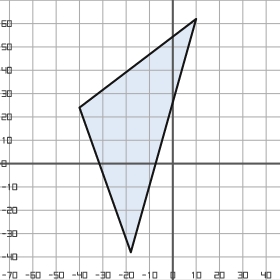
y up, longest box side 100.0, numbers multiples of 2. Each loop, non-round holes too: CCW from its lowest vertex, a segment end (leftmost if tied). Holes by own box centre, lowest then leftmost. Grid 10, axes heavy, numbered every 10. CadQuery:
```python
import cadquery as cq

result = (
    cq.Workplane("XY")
    .moveTo(-18.0, -38.0)
    .lineTo(10.0, 62.0)
    .lineTo(-40.0, 24.0)
    .close()
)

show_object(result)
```